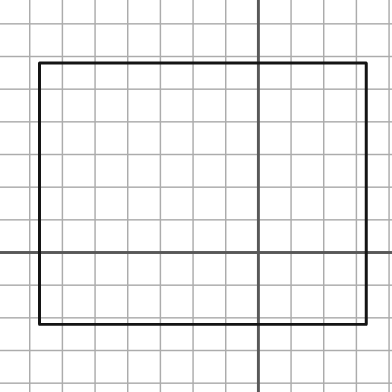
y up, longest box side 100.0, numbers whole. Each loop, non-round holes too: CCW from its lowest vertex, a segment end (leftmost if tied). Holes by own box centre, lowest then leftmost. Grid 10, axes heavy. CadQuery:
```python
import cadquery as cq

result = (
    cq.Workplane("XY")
    .moveTo(-67.0, -22.0)
    .lineTo(33.0, -22.0)
    .lineTo(33.0, 58.0)
    .lineTo(-67.0, 58.0)
    .close()
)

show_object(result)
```